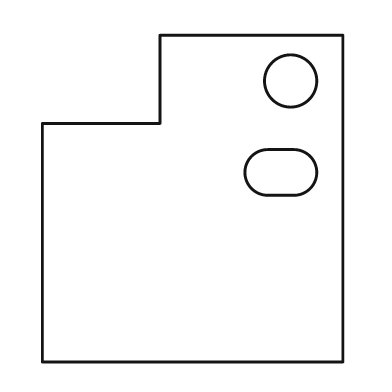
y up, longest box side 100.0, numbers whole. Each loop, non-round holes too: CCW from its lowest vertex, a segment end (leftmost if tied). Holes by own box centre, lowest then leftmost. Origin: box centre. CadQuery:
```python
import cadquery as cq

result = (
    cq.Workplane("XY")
    .moveTo(-46.0, -50.0)
    .lineTo(46.0, -50.0)
    .lineTo(46.0, 50.0)
    .lineTo(-10.0, 50.0)
    .lineTo(-10.0, 23.0)
    .lineTo(-46.0, 23.0)
    .close()
    .moveTo(23.0, 1.0)
    .lineTo(31.0, 1.0)
    .threePointArc((38.0, 8.0), (31.0, 15.0))
    .lineTo(23.0, 15.0)
    .threePointArc((16.0, 8.0), (23.0, 1.0))
    .close()
    .moveTo(30.0, 36.0)
    .circle(8.0)
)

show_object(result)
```